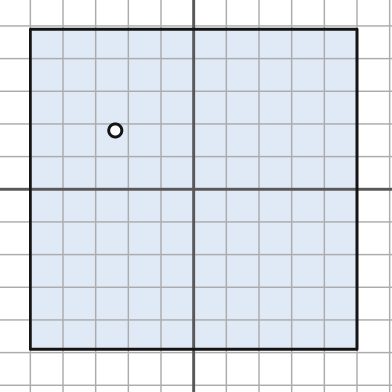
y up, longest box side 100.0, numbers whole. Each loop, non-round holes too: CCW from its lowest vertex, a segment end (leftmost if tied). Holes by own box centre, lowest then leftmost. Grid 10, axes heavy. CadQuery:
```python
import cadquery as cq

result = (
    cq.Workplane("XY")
    .moveTo(-50.0, -49.0)
    .lineTo(50.0, -49.0)
    .lineTo(50.0, 49.0)
    .lineTo(-50.0, 49.0)
    .close()
    .moveTo(-24.0, 18.0)
    .circle(2.0)
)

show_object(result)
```